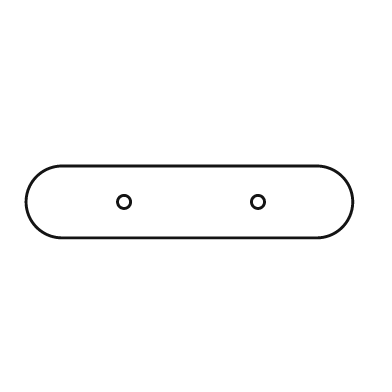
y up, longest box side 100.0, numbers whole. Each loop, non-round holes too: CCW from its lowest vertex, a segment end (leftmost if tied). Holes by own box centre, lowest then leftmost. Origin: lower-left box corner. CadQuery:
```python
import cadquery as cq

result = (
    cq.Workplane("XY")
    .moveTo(11.0, 0.0)
    .lineTo(89.0, 0.0)
    .threePointArc((100.0, 11.0), (89.0, 22.0))
    .lineTo(11.0, 22.0)
    .threePointArc((0.0, 11.0), (11.0, 0.0))
    .close()
    .moveTo(30.0, 11.0)
    .circle(2.0)
    .moveTo(71.0, 11.0)
    .circle(2.0)
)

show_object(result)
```